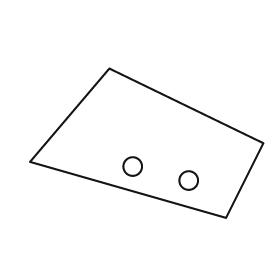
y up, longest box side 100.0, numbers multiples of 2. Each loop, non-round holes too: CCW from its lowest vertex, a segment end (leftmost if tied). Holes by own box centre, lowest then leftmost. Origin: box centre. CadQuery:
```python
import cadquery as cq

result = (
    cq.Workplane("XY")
    .moveTo(34.0, -32.0)
    .lineTo(50.0, 0.0)
    .lineTo(-16.0, 32.0)
    .lineTo(-50.0, -8.0)
    .close()
    .moveTo(18.0, -16.0)
    .circle(4.0)
    .moveTo(-6.0, -10.0)
    .circle(4.0)
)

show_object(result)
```